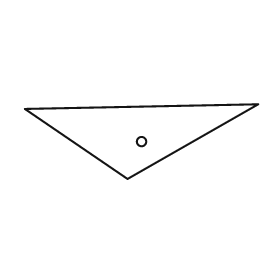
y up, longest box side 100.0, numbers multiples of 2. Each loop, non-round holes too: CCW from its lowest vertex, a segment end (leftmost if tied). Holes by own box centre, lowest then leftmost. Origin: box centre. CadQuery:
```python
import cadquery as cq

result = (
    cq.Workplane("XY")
    .moveTo(-6.0, -16.0)
    .lineTo(50.0, 16.0)
    .lineTo(-50.0, 14.0)
    .close()
    .moveTo(0.0, 0.0)
    .circle(2.0)
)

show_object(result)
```